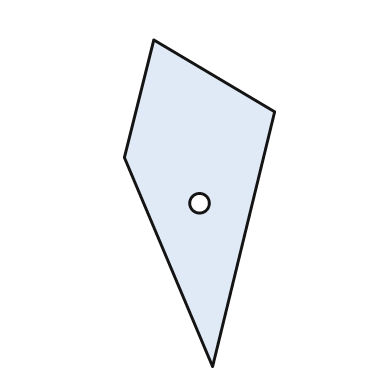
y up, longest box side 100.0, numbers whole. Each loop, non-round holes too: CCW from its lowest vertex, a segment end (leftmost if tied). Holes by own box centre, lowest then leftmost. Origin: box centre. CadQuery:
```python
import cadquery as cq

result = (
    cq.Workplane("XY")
    .moveTo(4.0, -50.0)
    .lineTo(23.0, 28.0)
    .lineTo(-14.0, 50.0)
    .lineTo(-23.0, 14.0)
    .close()
    .moveTo(0.0, 0.0)
    .circle(3.0)
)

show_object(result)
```